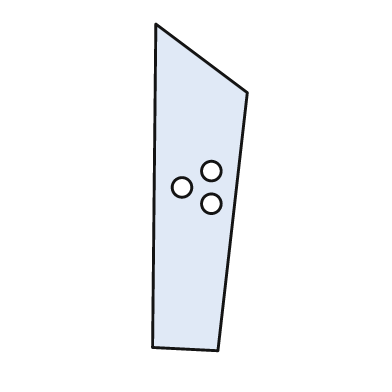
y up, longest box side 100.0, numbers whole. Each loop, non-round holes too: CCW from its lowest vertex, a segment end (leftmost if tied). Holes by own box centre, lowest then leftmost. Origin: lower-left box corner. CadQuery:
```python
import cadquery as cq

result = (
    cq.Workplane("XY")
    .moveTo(20.0, 0.0)
    .lineTo(29.0, 79.0)
    .lineTo(1.0, 100.0)
    .lineTo(0.0, 1.0)
    .close()
    .moveTo(18.0, 45.0)
    .circle(3.0)
    .moveTo(9.0, 50.0)
    .circle(3.0)
    .moveTo(18.0, 55.0)
    .circle(3.0)
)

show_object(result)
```